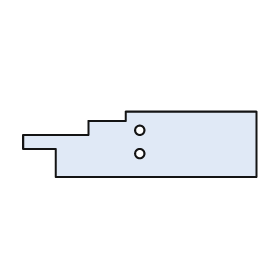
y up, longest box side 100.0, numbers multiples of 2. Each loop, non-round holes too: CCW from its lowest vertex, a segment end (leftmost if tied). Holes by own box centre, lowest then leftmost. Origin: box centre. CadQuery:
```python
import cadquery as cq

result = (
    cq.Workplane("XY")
    .moveTo(-36.0, -14.0)
    .lineTo(50.0, -14.0)
    .lineTo(50.0, 14.0)
    .lineTo(-6.0, 14.0)
    .lineTo(-6.0, 10.0)
    .lineTo(-22.0, 10.0)
    .lineTo(-22.0, 4.0)
    .lineTo(-50.0, 4.0)
    .lineTo(-50.0, -2.0)
    .lineTo(-36.0, -2.0)
    .close()
    .moveTo(0.0, -4.0)
    .circle(2.0)
    .moveTo(0.0, 6.0)
    .circle(2.0)
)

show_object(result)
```